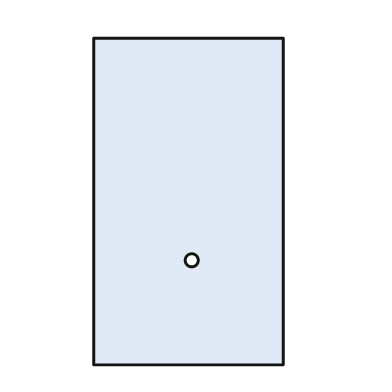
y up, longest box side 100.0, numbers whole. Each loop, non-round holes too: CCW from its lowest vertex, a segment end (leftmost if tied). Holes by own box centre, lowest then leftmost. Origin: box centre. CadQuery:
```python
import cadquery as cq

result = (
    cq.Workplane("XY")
    .moveTo(-29.0, -50.0)
    .lineTo(29.0, -50.0)
    .lineTo(29.0, 50.0)
    .lineTo(-29.0, 50.0)
    .close()
    .moveTo(1.0, -18.0)
    .circle(2.0)
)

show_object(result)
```